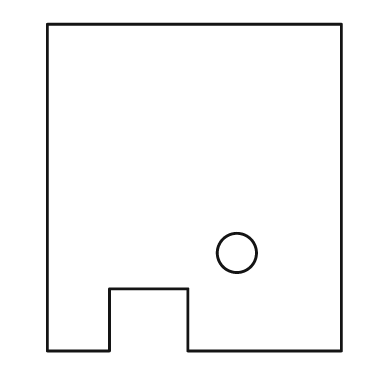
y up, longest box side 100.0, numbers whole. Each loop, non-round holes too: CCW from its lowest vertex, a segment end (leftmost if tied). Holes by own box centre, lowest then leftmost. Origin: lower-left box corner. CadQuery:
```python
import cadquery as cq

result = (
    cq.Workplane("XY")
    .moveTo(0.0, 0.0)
    .lineTo(19.0, 0.0)
    .lineTo(19.0, 19.0)
    .lineTo(43.0, 19.0)
    .lineTo(43.0, 0.0)
    .lineTo(90.0, 0.0)
    .lineTo(90.0, 100.0)
    .lineTo(0.0, 100.0)
    .close()
    .moveTo(58.0, 30.0)
    .circle(6.0)
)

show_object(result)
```